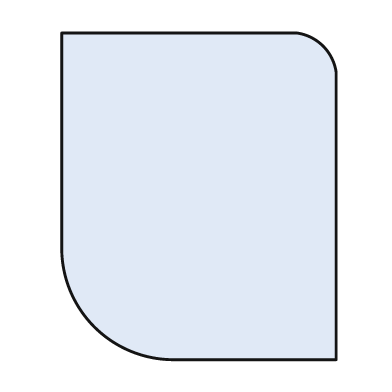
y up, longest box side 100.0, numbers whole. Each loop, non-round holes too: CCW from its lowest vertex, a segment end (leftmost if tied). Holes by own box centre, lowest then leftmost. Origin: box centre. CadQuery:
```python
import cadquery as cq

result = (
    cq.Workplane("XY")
    .moveTo(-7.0, -50.0)
    .lineTo(42.0, -50.0)
    .lineTo(42.0, 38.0)
    .threePointArc((38.0, 46.0), (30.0, 50.0))
    .lineTo(-42.0, 50.0)
    .lineTo(-42.0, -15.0)
    .threePointArc((-32.0, -40.0), (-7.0, -50.0))
    .close()
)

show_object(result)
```